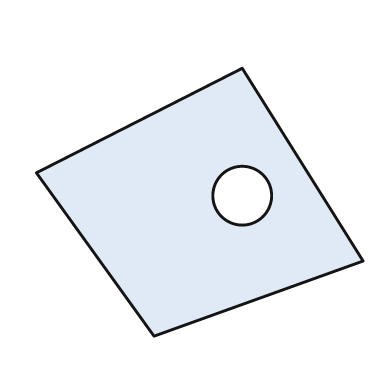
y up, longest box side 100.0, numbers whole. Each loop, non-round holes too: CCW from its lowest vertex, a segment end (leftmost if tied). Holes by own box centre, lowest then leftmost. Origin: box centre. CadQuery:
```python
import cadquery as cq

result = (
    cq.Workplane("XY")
    .moveTo(-14.0, -41.0)
    .lineTo(50.0, -18.0)
    .lineTo(13.0, 41.0)
    .lineTo(-50.0, 9.0)
    .close()
    .moveTo(13.0, 2.0)
    .circle(9.0)
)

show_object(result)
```